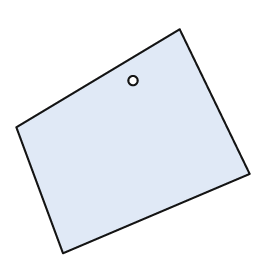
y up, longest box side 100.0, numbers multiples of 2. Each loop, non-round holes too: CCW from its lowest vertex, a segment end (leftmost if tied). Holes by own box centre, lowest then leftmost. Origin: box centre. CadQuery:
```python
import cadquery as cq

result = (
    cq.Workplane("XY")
    .moveTo(-30.0, -48.0)
    .lineTo(50.0, -14.0)
    .lineTo(20.0, 48.0)
    .lineTo(-50.0, 6.0)
    .close()
    .moveTo(0.0, 26.0)
    .circle(2.0)
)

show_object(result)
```